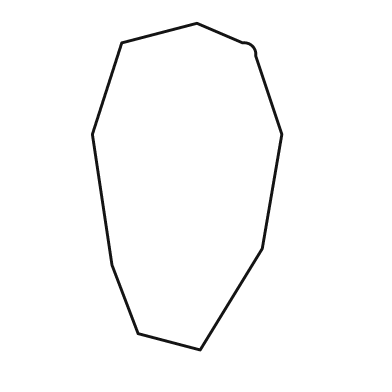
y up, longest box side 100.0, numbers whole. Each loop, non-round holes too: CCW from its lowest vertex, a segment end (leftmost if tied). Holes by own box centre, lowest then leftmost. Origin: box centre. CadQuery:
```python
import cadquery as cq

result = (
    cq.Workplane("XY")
    .moveTo(4.0, -50.0)
    .lineTo(23.0, -19.0)
    .lineTo(29.0, 16.0)
    .lineTo(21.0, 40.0)
    .threePointArc((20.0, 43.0), (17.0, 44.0))
    .lineTo(3.0, 50.0)
    .lineTo(-20.0, 44.0)
    .lineTo(-29.0, 16.0)
    .lineTo(-23.0, -24.0)
    .lineTo(-15.0, -45.0)
    .close()
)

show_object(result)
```